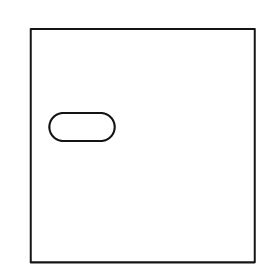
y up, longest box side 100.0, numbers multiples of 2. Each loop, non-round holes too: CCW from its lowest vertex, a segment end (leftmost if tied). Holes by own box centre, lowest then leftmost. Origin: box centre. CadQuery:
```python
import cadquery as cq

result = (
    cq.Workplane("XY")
    .moveTo(-48.0, -50.0)
    .lineTo(48.0, -50.0)
    .lineTo(48.0, 50.0)
    .lineTo(-48.0, 50.0)
    .close()
    .moveTo(-34.0, 2.0)
    .lineTo(-18.0, 2.0)
    .threePointArc((-12.0, 8.0), (-18.0, 14.0))
    .lineTo(-34.0, 14.0)
    .threePointArc((-40.0, 8.0), (-34.0, 2.0))
    .close()
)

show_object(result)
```